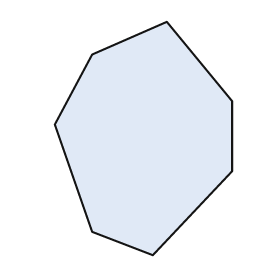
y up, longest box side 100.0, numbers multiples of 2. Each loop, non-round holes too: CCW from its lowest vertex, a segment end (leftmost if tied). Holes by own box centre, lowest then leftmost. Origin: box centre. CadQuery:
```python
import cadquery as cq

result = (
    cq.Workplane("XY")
    .moveTo(4.0, -50.0)
    .lineTo(38.0, -14.0)
    .lineTo(38.0, 16.0)
    .lineTo(10.0, 50.0)
    .lineTo(-22.0, 36.0)
    .lineTo(-38.0, 6.0)
    .lineTo(-22.0, -40.0)
    .close()
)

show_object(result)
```